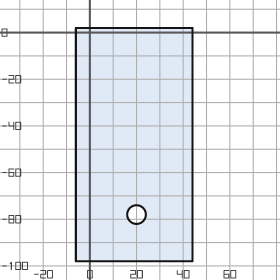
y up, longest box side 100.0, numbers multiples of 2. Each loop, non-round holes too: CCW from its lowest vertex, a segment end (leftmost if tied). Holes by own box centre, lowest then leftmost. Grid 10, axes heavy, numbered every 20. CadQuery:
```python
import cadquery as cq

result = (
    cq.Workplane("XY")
    .moveTo(-6.0, -98.0)
    .lineTo(44.0, -98.0)
    .lineTo(44.0, 2.0)
    .lineTo(-6.0, 2.0)
    .close()
    .moveTo(20.0, -78.0)
    .circle(4.0)
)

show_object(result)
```